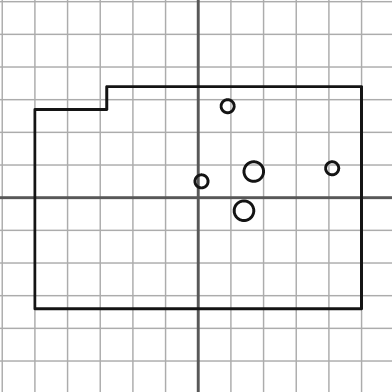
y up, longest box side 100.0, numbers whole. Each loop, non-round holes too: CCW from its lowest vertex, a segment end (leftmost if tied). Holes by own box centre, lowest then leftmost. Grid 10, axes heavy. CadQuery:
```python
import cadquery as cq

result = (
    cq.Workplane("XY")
    .moveTo(-50.0, -34.0)
    .lineTo(50.0, -34.0)
    .lineTo(50.0, 34.0)
    .lineTo(-28.0, 34.0)
    .lineTo(-28.0, 27.0)
    .lineTo(-50.0, 27.0)
    .close()
    .moveTo(14.0, -4.0)
    .circle(3.0)
    .moveTo(1.0, 5.0)
    .circle(2.0)
    .moveTo(17.0, 8.0)
    .circle(3.0)
    .moveTo(41.0, 9.0)
    .circle(2.0)
    .moveTo(9.0, 28.0)
    .circle(2.0)
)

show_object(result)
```